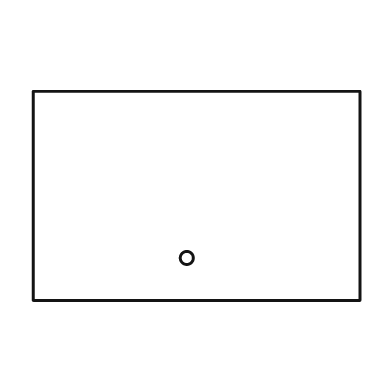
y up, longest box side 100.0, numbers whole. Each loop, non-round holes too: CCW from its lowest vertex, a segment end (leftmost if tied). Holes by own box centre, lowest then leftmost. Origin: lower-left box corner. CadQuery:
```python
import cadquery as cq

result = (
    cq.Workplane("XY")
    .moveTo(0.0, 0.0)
    .lineTo(100.0, 0.0)
    .lineTo(100.0, 64.0)
    .lineTo(0.0, 64.0)
    .close()
    .moveTo(47.0, 13.0)
    .circle(2.0)
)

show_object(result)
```